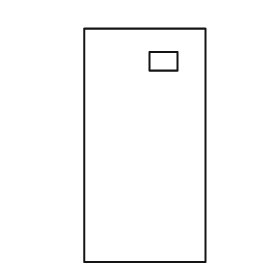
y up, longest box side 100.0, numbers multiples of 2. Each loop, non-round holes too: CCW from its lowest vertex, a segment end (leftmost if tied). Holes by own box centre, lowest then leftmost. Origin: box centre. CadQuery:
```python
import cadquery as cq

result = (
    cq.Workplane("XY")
    .moveTo(-26.0, -50.0)
    .lineTo(26.0, -50.0)
    .lineTo(26.0, 50.0)
    .lineTo(-26.0, 50.0)
    .close()
    .moveTo(2.0, 32.0)
    .lineTo(14.0, 32.0)
    .lineTo(14.0, 40.0)
    .lineTo(2.0, 40.0)
    .close()
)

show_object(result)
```